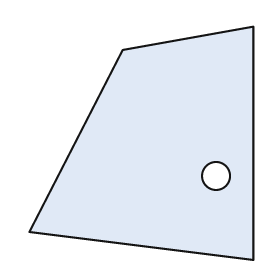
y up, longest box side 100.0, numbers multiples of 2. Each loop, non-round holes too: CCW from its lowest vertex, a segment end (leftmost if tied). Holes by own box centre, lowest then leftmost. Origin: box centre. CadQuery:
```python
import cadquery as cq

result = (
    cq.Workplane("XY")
    .moveTo(48.0, -50.0)
    .lineTo(48.0, 50.0)
    .lineTo(-8.0, 40.0)
    .lineTo(-48.0, -38.0)
    .close()
    .moveTo(32.0, -14.0)
    .circle(6.0)
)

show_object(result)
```